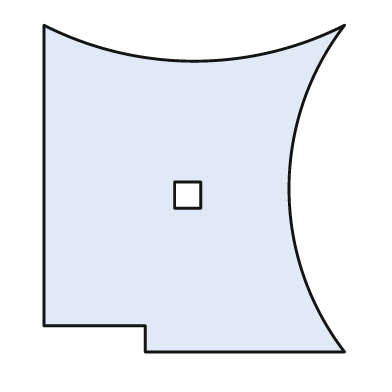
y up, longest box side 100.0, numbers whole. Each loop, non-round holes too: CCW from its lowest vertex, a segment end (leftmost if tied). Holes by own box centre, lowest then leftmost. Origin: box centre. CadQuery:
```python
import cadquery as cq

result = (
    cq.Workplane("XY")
    .moveTo(-15.0, -50.0)
    .lineTo(46.0, -50.0)
    .threePointArc((29.0, 0.0), (46.0, 50.0))
    .threePointArc((0.0, 39.0), (-46.0, 50.0))
    .lineTo(-46.0, -42.0)
    .lineTo(-15.0, -42.0)
    .close()
    .moveTo(-6.0, -6.0)
    .lineTo(2.0, -6.0)
    .lineTo(2.0, 2.0)
    .lineTo(-6.0, 2.0)
    .close()
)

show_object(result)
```